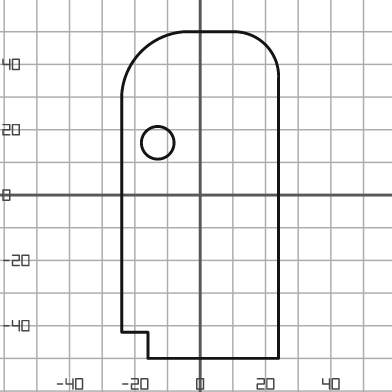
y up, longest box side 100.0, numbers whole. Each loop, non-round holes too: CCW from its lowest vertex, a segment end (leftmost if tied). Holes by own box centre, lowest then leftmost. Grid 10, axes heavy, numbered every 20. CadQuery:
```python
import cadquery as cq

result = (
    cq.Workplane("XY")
    .moveTo(-16.0, -50.0)
    .lineTo(24.0, -50.0)
    .lineTo(24.0, 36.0)
    .threePointArc((20.0, 46.0), (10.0, 50.0))
    .lineTo(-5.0, 50.0)
    .threePointArc((-18.0, 44.0), (-24.0, 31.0))
    .lineTo(-24.0, -42.0)
    .lineTo(-16.0, -42.0)
    .close()
    .moveTo(-13.0, 16.0)
    .circle(5.0)
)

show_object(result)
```